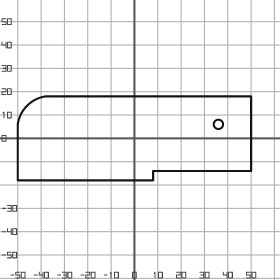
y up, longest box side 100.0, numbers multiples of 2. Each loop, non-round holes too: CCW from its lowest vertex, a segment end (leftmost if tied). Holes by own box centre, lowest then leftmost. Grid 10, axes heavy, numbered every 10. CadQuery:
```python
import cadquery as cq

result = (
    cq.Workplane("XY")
    .moveTo(-50.0, -18.0)
    .lineTo(8.0, -18.0)
    .lineTo(8.0, -14.0)
    .lineTo(50.0, -14.0)
    .lineTo(50.0, 18.0)
    .lineTo(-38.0, 18.0)
    .threePointArc((-46.0, 14.0), (-50.0, 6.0))
    .close()
    .moveTo(36.0, 6.0)
    .circle(2.0)
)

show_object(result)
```